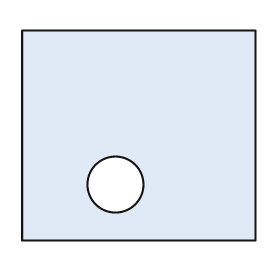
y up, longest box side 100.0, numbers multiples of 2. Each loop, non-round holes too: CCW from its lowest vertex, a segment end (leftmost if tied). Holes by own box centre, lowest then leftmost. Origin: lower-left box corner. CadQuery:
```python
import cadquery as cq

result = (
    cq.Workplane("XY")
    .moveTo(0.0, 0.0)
    .lineTo(100.0, 0.0)
    .lineTo(100.0, 90.0)
    .lineTo(0.0, 90.0)
    .close()
    .moveTo(40.0, 24.0)
    .circle(12.0)
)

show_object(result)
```